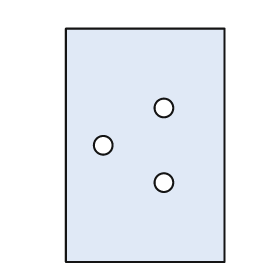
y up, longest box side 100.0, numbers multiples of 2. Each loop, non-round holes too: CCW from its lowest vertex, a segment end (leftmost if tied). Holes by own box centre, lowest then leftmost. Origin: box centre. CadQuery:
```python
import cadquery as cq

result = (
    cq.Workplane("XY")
    .moveTo(-34.0, -50.0)
    .lineTo(34.0, -50.0)
    .lineTo(34.0, 50.0)
    .lineTo(-34.0, 50.0)
    .close()
    .moveTo(8.0, -16.0)
    .circle(4.0)
    .moveTo(-18.0, 0.0)
    .circle(4.0)
    .moveTo(8.0, 16.0)
    .circle(4.0)
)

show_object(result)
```